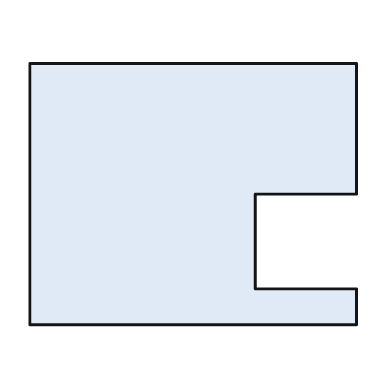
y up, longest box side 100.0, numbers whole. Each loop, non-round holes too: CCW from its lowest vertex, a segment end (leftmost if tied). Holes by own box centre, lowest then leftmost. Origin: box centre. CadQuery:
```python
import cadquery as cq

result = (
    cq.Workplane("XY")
    .moveTo(-50.0, -40.0)
    .lineTo(50.0, -40.0)
    .lineTo(50.0, -29.0)
    .lineTo(19.0, -29.0)
    .lineTo(19.0, 0.0)
    .lineTo(50.0, 0.0)
    .lineTo(50.0, 40.0)
    .lineTo(-50.0, 40.0)
    .close()
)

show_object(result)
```